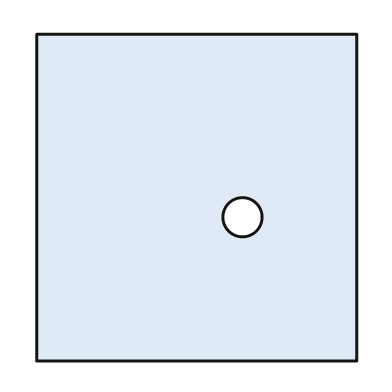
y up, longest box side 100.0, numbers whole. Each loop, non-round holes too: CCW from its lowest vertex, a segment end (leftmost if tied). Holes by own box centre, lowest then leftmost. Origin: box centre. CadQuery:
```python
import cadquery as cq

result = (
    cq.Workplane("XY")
    .moveTo(-49.0, -50.0)
    .lineTo(49.0, -50.0)
    .lineTo(49.0, 50.0)
    .lineTo(-49.0, 50.0)
    .close()
    .moveTo(14.0, -6.0)
    .circle(6.0)
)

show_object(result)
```